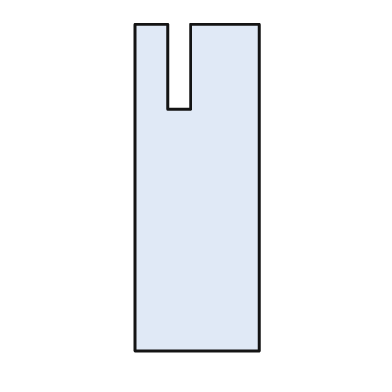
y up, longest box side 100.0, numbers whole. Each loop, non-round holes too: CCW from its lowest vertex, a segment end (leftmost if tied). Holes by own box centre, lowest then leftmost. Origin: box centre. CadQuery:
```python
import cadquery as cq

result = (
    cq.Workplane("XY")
    .moveTo(-19.0, -50.0)
    .lineTo(19.0, -50.0)
    .lineTo(19.0, 50.0)
    .lineTo(-2.0, 50.0)
    .lineTo(-2.0, 24.0)
    .lineTo(-9.0, 24.0)
    .lineTo(-9.0, 50.0)
    .lineTo(-19.0, 50.0)
    .close()
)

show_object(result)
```